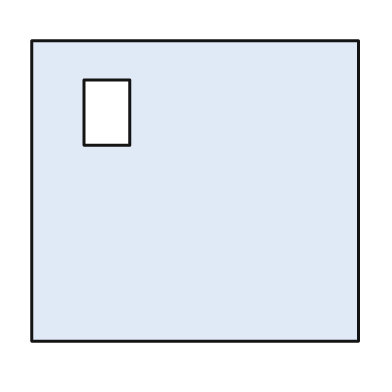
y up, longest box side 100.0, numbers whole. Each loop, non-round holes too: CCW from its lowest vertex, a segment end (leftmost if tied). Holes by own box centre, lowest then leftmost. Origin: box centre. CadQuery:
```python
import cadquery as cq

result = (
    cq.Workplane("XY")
    .moveTo(-50.0, -46.0)
    .lineTo(50.0, -46.0)
    .lineTo(50.0, 46.0)
    .lineTo(-50.0, 46.0)
    .close()
    .moveTo(-34.0, 14.0)
    .lineTo(-20.0, 14.0)
    .lineTo(-20.0, 34.0)
    .lineTo(-34.0, 34.0)
    .close()
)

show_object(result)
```